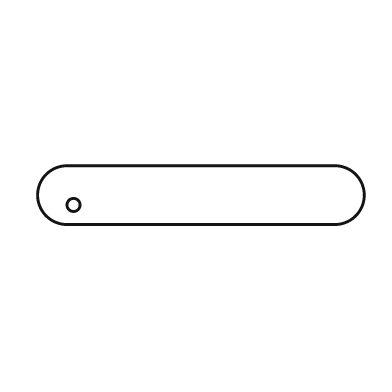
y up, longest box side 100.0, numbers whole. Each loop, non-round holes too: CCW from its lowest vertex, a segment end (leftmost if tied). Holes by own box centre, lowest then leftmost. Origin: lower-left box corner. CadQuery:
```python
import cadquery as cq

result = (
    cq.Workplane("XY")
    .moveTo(9.0, 0.0)
    .lineTo(91.0, 0.0)
    .threePointArc((100.0, 9.0), (91.0, 18.0))
    .lineTo(9.0, 18.0)
    .threePointArc((0.0, 9.0), (9.0, 0.0))
    .close()
    .moveTo(11.0, 6.0)
    .circle(2.0)
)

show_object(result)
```